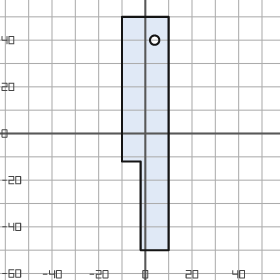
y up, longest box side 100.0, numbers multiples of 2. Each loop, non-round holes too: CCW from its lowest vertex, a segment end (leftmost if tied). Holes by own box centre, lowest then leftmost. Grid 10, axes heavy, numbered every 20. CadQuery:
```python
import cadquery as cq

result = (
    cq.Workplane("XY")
    .moveTo(-2.0, -50.0)
    .lineTo(10.0, -50.0)
    .lineTo(10.0, 50.0)
    .lineTo(-10.0, 50.0)
    .lineTo(-10.0, -12.0)
    .lineTo(-2.0, -12.0)
    .close()
    .moveTo(4.0, 40.0)
    .circle(2.0)
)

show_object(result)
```